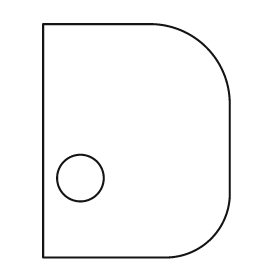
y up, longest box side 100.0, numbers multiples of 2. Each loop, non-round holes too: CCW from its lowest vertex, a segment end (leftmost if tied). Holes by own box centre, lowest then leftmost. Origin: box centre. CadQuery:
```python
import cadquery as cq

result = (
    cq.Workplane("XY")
    .moveTo(-40.0, -50.0)
    .lineTo(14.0, -50.0)
    .threePointArc((32.0, -42.0), (40.0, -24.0))
    .lineTo(40.0, 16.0)
    .threePointArc((30.0, 40.0), (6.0, 50.0))
    .lineTo(-40.0, 50.0)
    .close()
    .moveTo(-24.0, -16.0)
    .circle(10.0)
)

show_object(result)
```